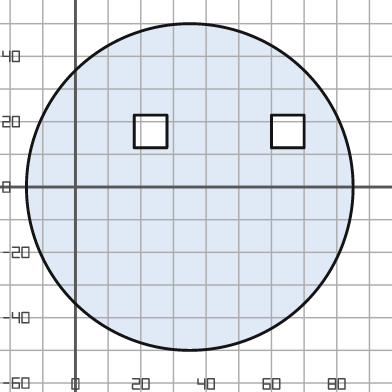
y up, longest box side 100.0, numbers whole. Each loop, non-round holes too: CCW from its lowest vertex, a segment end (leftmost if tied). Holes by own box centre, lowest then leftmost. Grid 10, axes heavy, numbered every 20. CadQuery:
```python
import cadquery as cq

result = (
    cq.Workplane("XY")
    .moveTo(35.0, 0.0)
    .circle(50.0)
    .moveTo(18.0, 12.0)
    .lineTo(28.0, 12.0)
    .lineTo(28.0, 22.0)
    .lineTo(18.0, 22.0)
    .close()
    .moveTo(60.0, 12.0)
    .lineTo(70.0, 12.0)
    .lineTo(70.0, 22.0)
    .lineTo(60.0, 22.0)
    .close()
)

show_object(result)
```